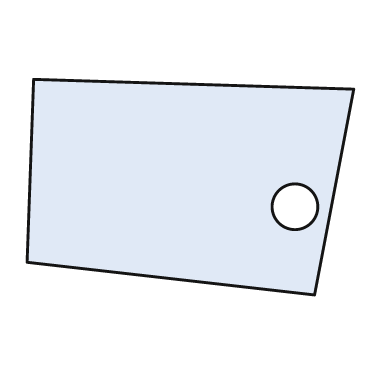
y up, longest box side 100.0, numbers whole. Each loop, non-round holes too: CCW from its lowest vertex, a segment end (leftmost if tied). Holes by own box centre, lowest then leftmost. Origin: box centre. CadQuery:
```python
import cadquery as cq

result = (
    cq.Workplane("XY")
    .moveTo(38.0, -33.0)
    .lineTo(50.0, 30.0)
    .lineTo(-48.0, 33.0)
    .lineTo(-50.0, -23.0)
    .close()
    .moveTo(32.0, -6.0)
    .circle(7.0)
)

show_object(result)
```